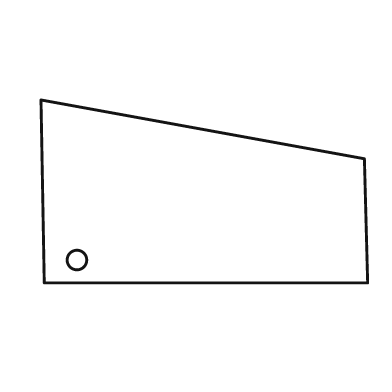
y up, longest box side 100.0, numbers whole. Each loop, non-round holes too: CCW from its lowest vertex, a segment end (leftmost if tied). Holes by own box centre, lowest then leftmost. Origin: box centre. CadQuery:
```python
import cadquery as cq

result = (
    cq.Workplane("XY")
    .moveTo(-49.0, -28.0)
    .lineTo(50.0, -28.0)
    .lineTo(49.0, 10.0)
    .lineTo(-50.0, 28.0)
    .close()
    .moveTo(-39.0, -21.0)
    .circle(3.0)
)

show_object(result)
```